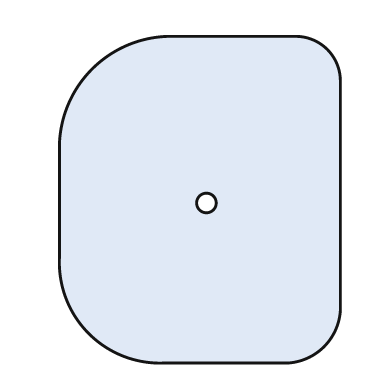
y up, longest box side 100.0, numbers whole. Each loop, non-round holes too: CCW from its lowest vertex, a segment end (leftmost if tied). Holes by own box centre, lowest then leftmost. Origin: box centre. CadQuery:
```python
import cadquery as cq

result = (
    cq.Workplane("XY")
    .moveTo(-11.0, -50.0)
    .lineTo(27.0, -50.0)
    .threePointArc((38.0, -45.0), (43.0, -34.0))
    .lineTo(43.0, 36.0)
    .threePointArc((39.0, 46.0), (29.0, 50.0))
    .lineTo(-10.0, 50.0)
    .threePointArc((-33.0, 40.0), (-43.0, 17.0))
    .lineTo(-43.0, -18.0)
    .threePointArc((-34.0, -41.0), (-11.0, -50.0))
    .close()
    .moveTo(2.0, -1.0)
    .circle(3.0)
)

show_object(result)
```